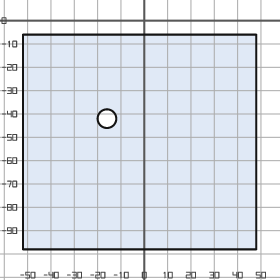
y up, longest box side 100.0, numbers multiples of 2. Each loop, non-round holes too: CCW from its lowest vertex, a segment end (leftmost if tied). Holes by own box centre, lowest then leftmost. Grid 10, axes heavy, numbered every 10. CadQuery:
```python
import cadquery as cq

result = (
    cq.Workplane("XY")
    .moveTo(-52.0, -98.0)
    .lineTo(48.0, -98.0)
    .lineTo(48.0, -6.0)
    .lineTo(-52.0, -6.0)
    .close()
    .moveTo(-16.0, -42.0)
    .circle(4.0)
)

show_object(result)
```